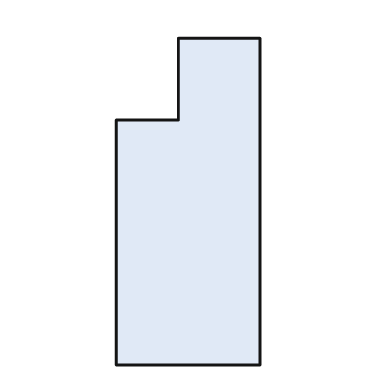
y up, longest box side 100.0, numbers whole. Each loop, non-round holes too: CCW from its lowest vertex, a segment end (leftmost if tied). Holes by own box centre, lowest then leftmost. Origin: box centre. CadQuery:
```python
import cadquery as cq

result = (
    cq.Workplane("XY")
    .moveTo(-22.0, -50.0)
    .lineTo(22.0, -50.0)
    .lineTo(22.0, 50.0)
    .lineTo(-3.0, 50.0)
    .lineTo(-3.0, 25.0)
    .lineTo(-22.0, 25.0)
    .close()
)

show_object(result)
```